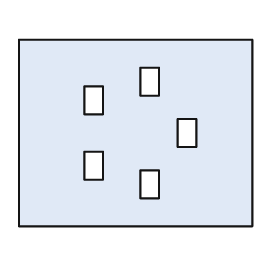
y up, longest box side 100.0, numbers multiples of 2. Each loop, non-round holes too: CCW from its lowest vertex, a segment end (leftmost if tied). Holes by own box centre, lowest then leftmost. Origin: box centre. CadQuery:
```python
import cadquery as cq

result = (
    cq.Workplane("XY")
    .moveTo(-50.0, -40.0)
    .lineTo(50.0, -40.0)
    .lineTo(50.0, 40.0)
    .lineTo(-50.0, 40.0)
    .close()
    .moveTo(2.0, -28.0)
    .lineTo(10.0, -28.0)
    .lineTo(10.0, -16.0)
    .lineTo(2.0, -16.0)
    .close()
    .moveTo(-22.0, -20.0)
    .lineTo(-14.0, -20.0)
    .lineTo(-14.0, -8.0)
    .lineTo(-22.0, -8.0)
    .close()
    .moveTo(18.0, -6.0)
    .lineTo(26.0, -6.0)
    .lineTo(26.0, 6.0)
    .lineTo(18.0, 6.0)
    .close()
    .moveTo(-22.0, 8.0)
    .lineTo(-14.0, 8.0)
    .lineTo(-14.0, 20.0)
    .lineTo(-22.0, 20.0)
    .close()
    .moveTo(2.0, 16.0)
    .lineTo(10.0, 16.0)
    .lineTo(10.0, 28.0)
    .lineTo(2.0, 28.0)
    .close()
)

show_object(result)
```